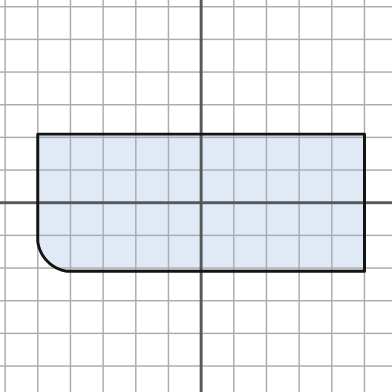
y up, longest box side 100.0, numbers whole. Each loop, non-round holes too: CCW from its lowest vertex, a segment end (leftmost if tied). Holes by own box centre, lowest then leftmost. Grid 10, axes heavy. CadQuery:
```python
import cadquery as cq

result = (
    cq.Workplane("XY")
    .moveTo(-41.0, -21.0)
    .lineTo(50.0, -21.0)
    .lineTo(50.0, 21.0)
    .lineTo(-50.0, 21.0)
    .lineTo(-50.0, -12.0)
    .threePointArc((-47.0, -18.0), (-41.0, -21.0))
    .close()
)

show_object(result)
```